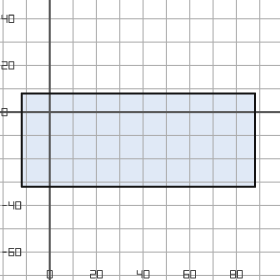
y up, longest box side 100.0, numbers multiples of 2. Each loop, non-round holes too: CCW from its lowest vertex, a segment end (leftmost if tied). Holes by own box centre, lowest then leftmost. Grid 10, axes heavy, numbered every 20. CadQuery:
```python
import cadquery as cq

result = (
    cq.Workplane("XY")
    .moveTo(-12.0, -32.0)
    .lineTo(88.0, -32.0)
    .lineTo(88.0, 8.0)
    .lineTo(-12.0, 8.0)
    .close()
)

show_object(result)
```